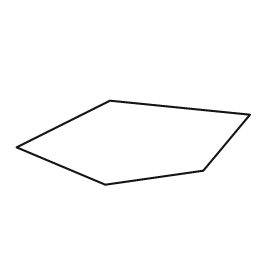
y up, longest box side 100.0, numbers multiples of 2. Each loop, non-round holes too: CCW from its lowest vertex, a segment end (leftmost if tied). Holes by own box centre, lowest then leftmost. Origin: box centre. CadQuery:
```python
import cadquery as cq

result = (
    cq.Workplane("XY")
    .moveTo(-12.0, -18.0)
    .lineTo(30.0, -12.0)
    .lineTo(50.0, 12.0)
    .lineTo(-10.0, 18.0)
    .lineTo(-50.0, -2.0)
    .close()
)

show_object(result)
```